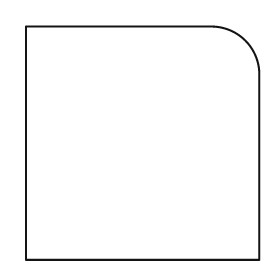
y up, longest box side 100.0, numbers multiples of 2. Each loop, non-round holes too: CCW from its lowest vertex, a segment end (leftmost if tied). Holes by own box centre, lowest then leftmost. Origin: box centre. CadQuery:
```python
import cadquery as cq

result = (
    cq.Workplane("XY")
    .moveTo(-50.0, -50.0)
    .lineTo(50.0, -50.0)
    .lineTo(50.0, 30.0)
    .threePointArc((44.0, 44.0), (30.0, 50.0))
    .lineTo(-50.0, 50.0)
    .close()
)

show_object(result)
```